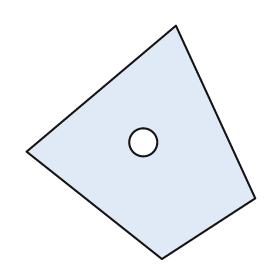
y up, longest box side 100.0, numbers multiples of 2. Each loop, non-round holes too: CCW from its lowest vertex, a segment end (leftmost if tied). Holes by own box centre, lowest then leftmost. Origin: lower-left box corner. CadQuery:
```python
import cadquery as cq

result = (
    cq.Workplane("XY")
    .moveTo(58.0, 0.0)
    .lineTo(98.0, 26.0)
    .lineTo(64.0, 100.0)
    .lineTo(0.0, 46.0)
    .close()
    .moveTo(50.0, 50.0)
    .circle(6.0)
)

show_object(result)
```